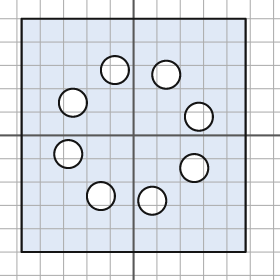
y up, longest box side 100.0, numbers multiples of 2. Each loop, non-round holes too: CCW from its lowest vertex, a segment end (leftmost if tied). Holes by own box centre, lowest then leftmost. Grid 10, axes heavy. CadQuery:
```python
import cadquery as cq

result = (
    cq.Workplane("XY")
    .moveTo(-48.0, -50.0)
    .lineTo(48.0, -50.0)
    .lineTo(48.0, 50.0)
    .lineTo(-48.0, 50.0)
    .close()
    .moveTo(8.0, -28.0)
    .circle(6.0)
    .moveTo(-14.0, -26.0)
    .circle(6.0)
    .moveTo(26.0, -14.0)
    .circle(6.0)
    .moveTo(-28.0, -8.0)
    .circle(6.0)
    .moveTo(28.0, 8.0)
    .circle(6.0)
    .moveTo(-26.0, 14.0)
    .circle(6.0)
    .moveTo(14.0, 26.0)
    .circle(6.0)
    .moveTo(-8.0, 28.0)
    .circle(6.0)
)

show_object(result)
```